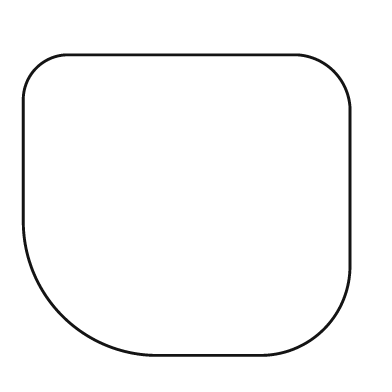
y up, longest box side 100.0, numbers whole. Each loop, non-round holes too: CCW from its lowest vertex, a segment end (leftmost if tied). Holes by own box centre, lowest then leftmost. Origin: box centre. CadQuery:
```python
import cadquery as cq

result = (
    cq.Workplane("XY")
    .moveTo(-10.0, -46.0)
    .lineTo(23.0, -46.0)
    .threePointArc((42.0, -38.0), (50.0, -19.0))
    .lineTo(50.0, 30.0)
    .threePointArc((45.0, 41.0), (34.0, 46.0))
    .lineTo(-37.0, 46.0)
    .threePointArc((-46.0, 42.0), (-50.0, 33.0))
    .lineTo(-50.0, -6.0)
    .threePointArc((-38.0, -34.0), (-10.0, -46.0))
    .close()
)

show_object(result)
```